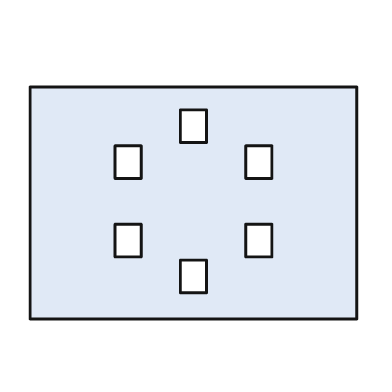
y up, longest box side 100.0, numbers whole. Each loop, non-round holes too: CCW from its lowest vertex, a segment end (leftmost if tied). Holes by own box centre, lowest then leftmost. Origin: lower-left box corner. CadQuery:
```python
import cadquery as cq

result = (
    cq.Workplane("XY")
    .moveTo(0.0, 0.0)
    .lineTo(100.0, 0.0)
    .lineTo(100.0, 71.0)
    .lineTo(0.0, 71.0)
    .close()
    .moveTo(46.0, 8.0)
    .lineTo(54.0, 8.0)
    .lineTo(54.0, 18.0)
    .lineTo(46.0, 18.0)
    .close()
    .moveTo(26.0, 19.0)
    .lineTo(34.0, 19.0)
    .lineTo(34.0, 29.0)
    .lineTo(26.0, 29.0)
    .close()
    .moveTo(66.0, 19.0)
    .lineTo(74.0, 19.0)
    .lineTo(74.0, 29.0)
    .lineTo(66.0, 29.0)
    .close()
    .moveTo(26.0, 43.0)
    .lineTo(34.0, 43.0)
    .lineTo(34.0, 53.0)
    .lineTo(26.0, 53.0)
    .close()
    .moveTo(66.0, 43.0)
    .lineTo(74.0, 43.0)
    .lineTo(74.0, 53.0)
    .lineTo(66.0, 53.0)
    .close()
    .moveTo(46.0, 54.0)
    .lineTo(54.0, 54.0)
    .lineTo(54.0, 64.0)
    .lineTo(46.0, 64.0)
    .close()
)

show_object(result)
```